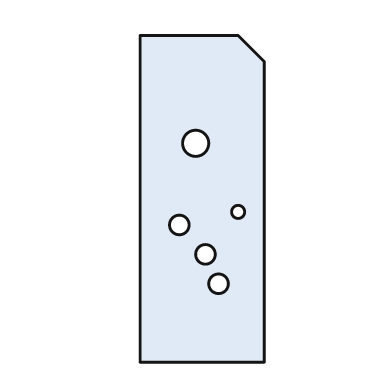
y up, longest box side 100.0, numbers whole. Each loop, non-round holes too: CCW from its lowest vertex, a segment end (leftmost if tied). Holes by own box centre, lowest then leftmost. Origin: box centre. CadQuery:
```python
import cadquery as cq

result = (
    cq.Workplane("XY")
    .moveTo(-19.0, -50.0)
    .lineTo(19.0, -50.0)
    .lineTo(19.0, 42.0)
    .lineTo(11.0, 50.0)
    .lineTo(-19.0, 50.0)
    .close()
    .moveTo(5.0, -26.0)
    .circle(3.0)
    .moveTo(1.0, -17.0)
    .circle(3.0)
    .moveTo(-7.0, -8.0)
    .circle(3.0)
    .moveTo(11.0, -4.0)
    .circle(2.0)
    .moveTo(-2.0, 17.0)
    .circle(4.0)
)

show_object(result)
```